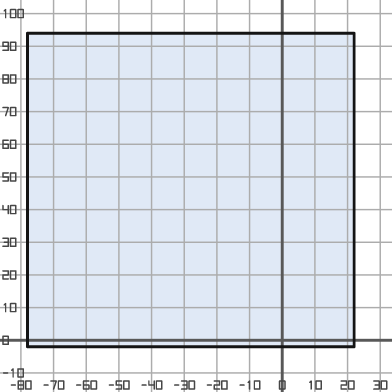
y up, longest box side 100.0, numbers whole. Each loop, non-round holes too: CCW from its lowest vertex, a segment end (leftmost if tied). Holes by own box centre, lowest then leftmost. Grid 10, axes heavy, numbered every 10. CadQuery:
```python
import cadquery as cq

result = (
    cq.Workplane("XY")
    .moveTo(-78.0, -2.0)
    .lineTo(22.0, -2.0)
    .lineTo(22.0, 94.0)
    .lineTo(-78.0, 94.0)
    .close()
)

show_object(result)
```